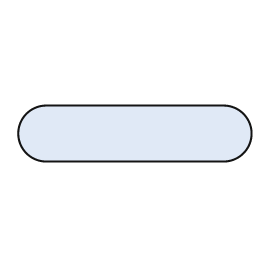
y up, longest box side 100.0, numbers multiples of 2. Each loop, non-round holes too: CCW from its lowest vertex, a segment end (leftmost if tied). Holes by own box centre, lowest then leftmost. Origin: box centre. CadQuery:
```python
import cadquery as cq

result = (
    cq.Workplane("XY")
    .moveTo(-38.0, -12.0)
    .lineTo(38.0, -12.0)
    .threePointArc((50.0, 0.0), (38.0, 12.0))
    .lineTo(-38.0, 12.0)
    .threePointArc((-50.0, 0.0), (-38.0, -12.0))
    .close()
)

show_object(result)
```